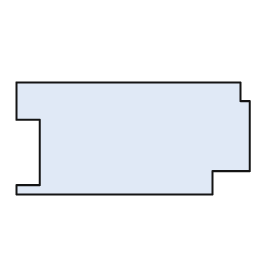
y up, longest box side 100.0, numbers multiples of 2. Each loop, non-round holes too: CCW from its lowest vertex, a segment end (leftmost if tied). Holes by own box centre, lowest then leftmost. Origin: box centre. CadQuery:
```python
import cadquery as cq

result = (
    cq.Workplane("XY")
    .moveTo(-50.0, -24.0)
    .lineTo(34.0, -24.0)
    .lineTo(34.0, -14.0)
    .lineTo(50.0, -14.0)
    .lineTo(50.0, 16.0)
    .lineTo(46.0, 16.0)
    .lineTo(46.0, 24.0)
    .lineTo(-50.0, 24.0)
    .lineTo(-50.0, 8.0)
    .lineTo(-40.0, 8.0)
    .lineTo(-40.0, -20.0)
    .lineTo(-50.0, -20.0)
    .close()
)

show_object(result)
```